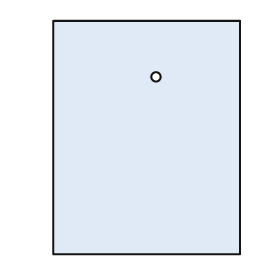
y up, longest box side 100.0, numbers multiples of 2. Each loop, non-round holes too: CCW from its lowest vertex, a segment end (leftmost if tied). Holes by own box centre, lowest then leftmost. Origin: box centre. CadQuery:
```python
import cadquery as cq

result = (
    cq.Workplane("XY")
    .moveTo(-40.0, -50.0)
    .lineTo(40.0, -50.0)
    .lineTo(40.0, 50.0)
    .lineTo(-40.0, 50.0)
    .close()
    .moveTo(4.0, 26.0)
    .circle(2.0)
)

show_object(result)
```